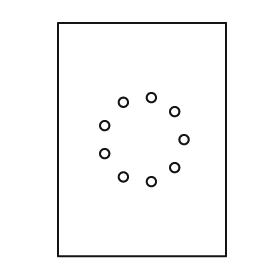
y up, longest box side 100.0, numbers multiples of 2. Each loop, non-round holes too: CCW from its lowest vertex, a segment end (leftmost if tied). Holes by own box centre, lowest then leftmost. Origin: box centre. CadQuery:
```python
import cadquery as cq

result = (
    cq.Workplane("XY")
    .moveTo(-36.0, -50.0)
    .lineTo(36.0, -50.0)
    .lineTo(36.0, 50.0)
    .lineTo(-36.0, 50.0)
    .close()
    .moveTo(4.0, -18.0)
    .circle(2.0)
    .moveTo(-8.0, -16.0)
    .circle(2.0)
    .moveTo(14.0, -12.0)
    .circle(2.0)
    .moveTo(-16.0, -6.0)
    .circle(2.0)
    .moveTo(18.0, 0.0)
    .circle(2.0)
    .moveTo(-16.0, 6.0)
    .circle(2.0)
    .moveTo(14.0, 12.0)
    .circle(2.0)
    .moveTo(-8.0, 16.0)
    .circle(2.0)
    .moveTo(4.0, 18.0)
    .circle(2.0)
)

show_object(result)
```